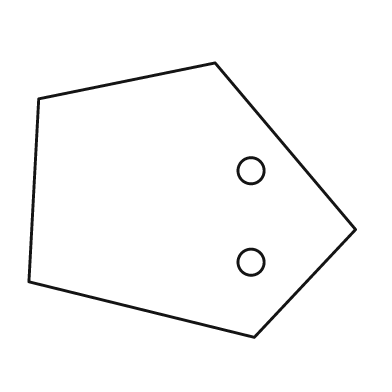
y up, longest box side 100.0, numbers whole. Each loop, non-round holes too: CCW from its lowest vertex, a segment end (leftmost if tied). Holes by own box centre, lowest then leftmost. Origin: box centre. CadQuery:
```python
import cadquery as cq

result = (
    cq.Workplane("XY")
    .moveTo(19.0, -42.0)
    .lineTo(50.0, -9.0)
    .lineTo(7.0, 42.0)
    .lineTo(-47.0, 31.0)
    .lineTo(-50.0, -25.0)
    .close()
    .moveTo(18.0, -19.0)
    .circle(4.0)
    .moveTo(18.0, 9.0)
    .circle(4.0)
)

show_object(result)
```